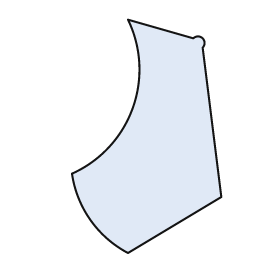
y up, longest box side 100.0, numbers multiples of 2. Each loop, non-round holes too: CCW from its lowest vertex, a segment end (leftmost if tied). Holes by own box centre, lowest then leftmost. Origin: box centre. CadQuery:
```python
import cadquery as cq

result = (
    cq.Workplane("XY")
    .moveTo(-8.0, -50.0)
    .lineTo(32.0, -26.0)
    .lineTo(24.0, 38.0)
    .threePointArc((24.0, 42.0), (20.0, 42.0))
    .lineTo(-8.0, 50.0)
    .threePointArc((-6.0, 12.0), (-32.0, -16.0))
    .threePointArc((-24.0, -36.0), (-8.0, -50.0))
    .close()
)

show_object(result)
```